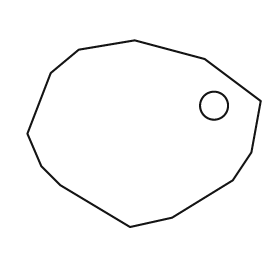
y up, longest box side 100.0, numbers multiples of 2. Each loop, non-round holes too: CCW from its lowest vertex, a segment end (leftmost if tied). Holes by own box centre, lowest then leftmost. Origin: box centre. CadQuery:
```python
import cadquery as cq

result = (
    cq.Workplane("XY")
    .moveTo(-6.0, -40.0)
    .lineTo(12.0, -36.0)
    .lineTo(38.0, -20.0)
    .lineTo(46.0, -8.0)
    .lineTo(50.0, 14.0)
    .lineTo(26.0, 32.0)
    .lineTo(-4.0, 40.0)
    .lineTo(-28.0, 36.0)
    .lineTo(-40.0, 26.0)
    .lineTo(-50.0, 0.0)
    .lineTo(-44.0, -14.0)
    .lineTo(-36.0, -22.0)
    .close()
    .moveTo(30.0, 12.0)
    .circle(6.0)
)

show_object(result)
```